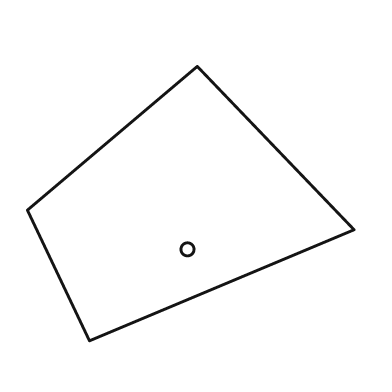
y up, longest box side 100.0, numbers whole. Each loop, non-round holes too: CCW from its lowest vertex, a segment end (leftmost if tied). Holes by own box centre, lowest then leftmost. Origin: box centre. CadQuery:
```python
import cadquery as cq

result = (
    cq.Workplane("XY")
    .moveTo(-31.0, -42.0)
    .lineTo(50.0, -8.0)
    .lineTo(2.0, 42.0)
    .lineTo(-50.0, -2.0)
    .close()
    .moveTo(-1.0, -14.0)
    .circle(2.0)
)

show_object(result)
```